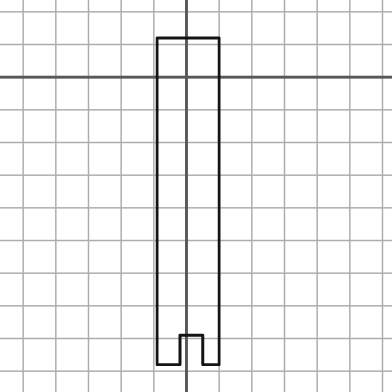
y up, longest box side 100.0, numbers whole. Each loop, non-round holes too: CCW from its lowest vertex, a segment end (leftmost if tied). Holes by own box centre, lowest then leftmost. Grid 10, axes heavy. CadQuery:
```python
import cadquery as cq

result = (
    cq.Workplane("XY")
    .moveTo(-9.0, -88.0)
    .lineTo(-2.0, -88.0)
    .lineTo(-2.0, -79.0)
    .lineTo(5.0, -79.0)
    .lineTo(5.0, -88.0)
    .lineTo(10.0, -88.0)
    .lineTo(10.0, 12.0)
    .lineTo(-9.0, 12.0)
    .close()
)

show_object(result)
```